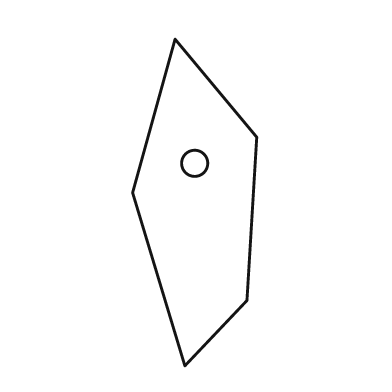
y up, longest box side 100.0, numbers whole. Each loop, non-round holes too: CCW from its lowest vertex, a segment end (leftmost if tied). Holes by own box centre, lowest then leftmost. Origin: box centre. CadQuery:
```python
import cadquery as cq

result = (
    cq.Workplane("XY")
    .moveTo(-3.0, -50.0)
    .lineTo(16.0, -30.0)
    .lineTo(19.0, 20.0)
    .lineTo(-6.0, 50.0)
    .lineTo(-19.0, 3.0)
    .close()
    .moveTo(0.0, 12.0)
    .circle(4.0)
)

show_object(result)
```